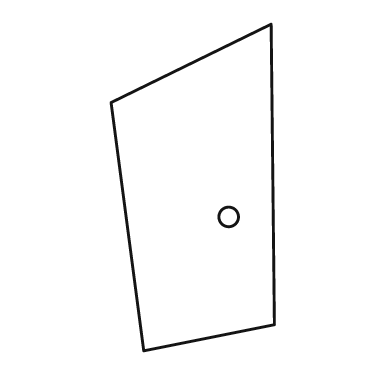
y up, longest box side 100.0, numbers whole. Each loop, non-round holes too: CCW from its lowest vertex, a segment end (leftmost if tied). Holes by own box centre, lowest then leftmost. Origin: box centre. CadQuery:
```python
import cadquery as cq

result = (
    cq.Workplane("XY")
    .moveTo(-15.0, -50.0)
    .lineTo(25.0, -42.0)
    .lineTo(24.0, 50.0)
    .lineTo(-25.0, 26.0)
    .close()
    .moveTo(11.0, -9.0)
    .circle(3.0)
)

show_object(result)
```